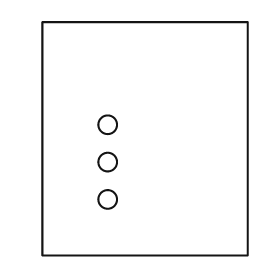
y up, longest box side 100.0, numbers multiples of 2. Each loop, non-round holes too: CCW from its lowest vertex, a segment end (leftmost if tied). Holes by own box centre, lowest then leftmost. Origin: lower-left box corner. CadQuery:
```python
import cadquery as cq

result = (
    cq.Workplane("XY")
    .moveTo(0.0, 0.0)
    .lineTo(88.0, 0.0)
    .lineTo(88.0, 100.0)
    .lineTo(0.0, 100.0)
    .close()
    .moveTo(28.0, 24.0)
    .circle(4.0)
    .moveTo(28.0, 40.0)
    .circle(4.0)
    .moveTo(28.0, 56.0)
    .circle(4.0)
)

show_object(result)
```